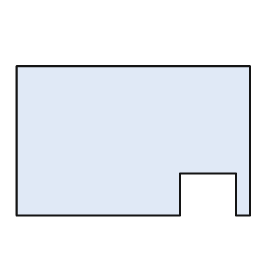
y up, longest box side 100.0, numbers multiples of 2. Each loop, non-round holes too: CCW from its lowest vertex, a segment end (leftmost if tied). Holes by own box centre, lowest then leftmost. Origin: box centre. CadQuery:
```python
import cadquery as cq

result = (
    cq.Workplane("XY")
    .moveTo(-50.0, -32.0)
    .lineTo(20.0, -32.0)
    .lineTo(20.0, -14.0)
    .lineTo(44.0, -14.0)
    .lineTo(44.0, -32.0)
    .lineTo(50.0, -32.0)
    .lineTo(50.0, 32.0)
    .lineTo(-50.0, 32.0)
    .close()
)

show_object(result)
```